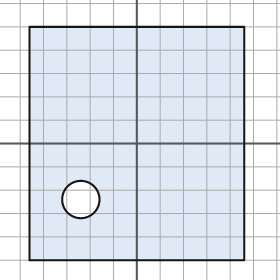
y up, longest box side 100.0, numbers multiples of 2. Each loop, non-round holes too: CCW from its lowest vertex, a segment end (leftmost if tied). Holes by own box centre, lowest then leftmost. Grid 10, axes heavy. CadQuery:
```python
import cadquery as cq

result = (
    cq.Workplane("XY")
    .moveTo(-46.0, -50.0)
    .lineTo(46.0, -50.0)
    .lineTo(46.0, 50.0)
    .lineTo(-46.0, 50.0)
    .close()
    .moveTo(-24.0, -24.0)
    .circle(8.0)
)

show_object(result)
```